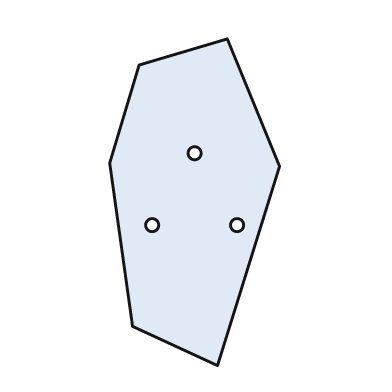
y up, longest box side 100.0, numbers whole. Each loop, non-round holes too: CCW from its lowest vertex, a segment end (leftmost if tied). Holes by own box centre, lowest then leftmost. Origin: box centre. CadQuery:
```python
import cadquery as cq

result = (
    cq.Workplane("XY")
    .moveTo(7.0, -50.0)
    .lineTo(26.0, 11.0)
    .lineTo(10.0, 50.0)
    .lineTo(-17.0, 42.0)
    .lineTo(-26.0, 12.0)
    .lineTo(-19.0, -38.0)
    .close()
    .moveTo(-13.0, -7.0)
    .circle(2.0)
    .moveTo(13.0, -7.0)
    .circle(2.0)
    .moveTo(0.0, 15.0)
    .circle(2.0)
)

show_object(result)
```